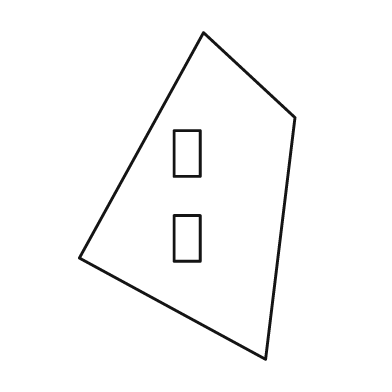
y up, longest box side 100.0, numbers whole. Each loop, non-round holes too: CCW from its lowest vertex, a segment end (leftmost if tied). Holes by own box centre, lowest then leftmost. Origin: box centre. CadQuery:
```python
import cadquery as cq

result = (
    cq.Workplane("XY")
    .moveTo(24.0, -50.0)
    .lineTo(33.0, 24.0)
    .lineTo(5.0, 50.0)
    .lineTo(-33.0, -19.0)
    .close()
    .moveTo(-4.0, -20.0)
    .lineTo(4.0, -20.0)
    .lineTo(4.0, -6.0)
    .lineTo(-4.0, -6.0)
    .close()
    .moveTo(-4.0, 6.0)
    .lineTo(4.0, 6.0)
    .lineTo(4.0, 20.0)
    .lineTo(-4.0, 20.0)
    .close()
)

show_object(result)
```